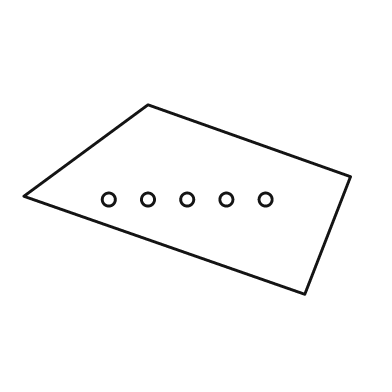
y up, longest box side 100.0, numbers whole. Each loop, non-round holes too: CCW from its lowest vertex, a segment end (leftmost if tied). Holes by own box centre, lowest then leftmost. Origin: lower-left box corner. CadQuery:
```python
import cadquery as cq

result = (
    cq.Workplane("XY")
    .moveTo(86.0, 0.0)
    .lineTo(100.0, 36.0)
    .lineTo(38.0, 58.0)
    .lineTo(0.0, 30.0)
    .close()
    .moveTo(26.0, 29.0)
    .circle(2.0)
    .moveTo(38.0, 29.0)
    .circle(2.0)
    .moveTo(50.0, 29.0)
    .circle(2.0)
    .moveTo(62.0, 29.0)
    .circle(2.0)
    .moveTo(74.0, 29.0)
    .circle(2.0)
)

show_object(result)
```